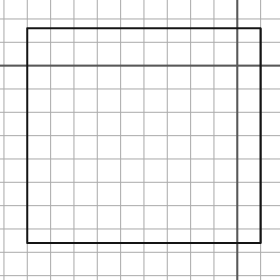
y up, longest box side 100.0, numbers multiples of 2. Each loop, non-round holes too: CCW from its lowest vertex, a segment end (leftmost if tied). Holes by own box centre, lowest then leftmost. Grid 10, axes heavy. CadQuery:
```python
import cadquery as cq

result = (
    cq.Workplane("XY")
    .moveTo(-90.0, -76.0)
    .lineTo(10.0, -76.0)
    .lineTo(10.0, 16.0)
    .lineTo(-90.0, 16.0)
    .close()
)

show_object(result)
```